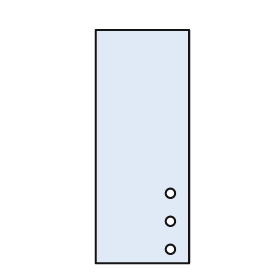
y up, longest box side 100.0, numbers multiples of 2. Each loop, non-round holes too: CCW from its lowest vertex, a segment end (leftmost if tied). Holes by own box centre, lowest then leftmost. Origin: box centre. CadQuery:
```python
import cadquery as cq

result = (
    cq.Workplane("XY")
    .moveTo(-20.0, -50.0)
    .lineTo(20.0, -50.0)
    .lineTo(20.0, 50.0)
    .lineTo(-20.0, 50.0)
    .close()
    .moveTo(12.0, -44.0)
    .circle(2.0)
    .moveTo(12.0, -32.0)
    .circle(2.0)
    .moveTo(12.0, -20.0)
    .circle(2.0)
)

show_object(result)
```